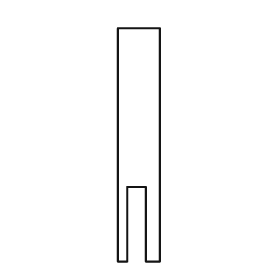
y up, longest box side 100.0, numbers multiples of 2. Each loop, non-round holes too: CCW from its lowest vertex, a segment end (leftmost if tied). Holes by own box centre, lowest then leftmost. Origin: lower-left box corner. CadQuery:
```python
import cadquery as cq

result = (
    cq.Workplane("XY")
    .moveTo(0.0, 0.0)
    .lineTo(4.0, 0.0)
    .lineTo(4.0, 32.0)
    .lineTo(12.0, 32.0)
    .lineTo(12.0, 0.0)
    .lineTo(18.0, 0.0)
    .lineTo(18.0, 100.0)
    .lineTo(0.0, 100.0)
    .close()
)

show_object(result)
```